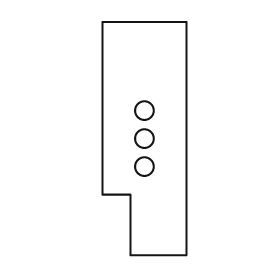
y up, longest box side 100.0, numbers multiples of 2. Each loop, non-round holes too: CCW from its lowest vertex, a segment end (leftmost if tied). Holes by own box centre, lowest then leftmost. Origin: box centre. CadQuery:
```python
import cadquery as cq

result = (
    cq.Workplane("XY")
    .moveTo(-6.0, -50.0)
    .lineTo(18.0, -50.0)
    .lineTo(18.0, 50.0)
    .lineTo(-18.0, 50.0)
    .lineTo(-18.0, -24.0)
    .lineTo(-6.0, -24.0)
    .close()
    .moveTo(0.0, -12.0)
    .circle(4.0)
    .moveTo(0.0, 0.0)
    .circle(4.0)
    .moveTo(0.0, 12.0)
    .circle(4.0)
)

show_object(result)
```